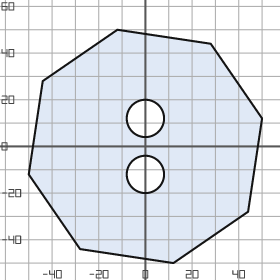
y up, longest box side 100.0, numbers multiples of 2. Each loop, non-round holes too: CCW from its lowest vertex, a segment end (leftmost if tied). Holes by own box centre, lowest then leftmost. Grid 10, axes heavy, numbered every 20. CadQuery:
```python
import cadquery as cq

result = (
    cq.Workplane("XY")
    .moveTo(12.0, -50.0)
    .lineTo(44.0, -28.0)
    .lineTo(50.0, 12.0)
    .lineTo(28.0, 44.0)
    .lineTo(-12.0, 50.0)
    .lineTo(-44.0, 28.0)
    .lineTo(-50.0, -12.0)
    .lineTo(-28.0, -44.0)
    .close()
    .moveTo(0.0, -12.0)
    .circle(8.0)
    .moveTo(0.0, 12.0)
    .circle(8.0)
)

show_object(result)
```